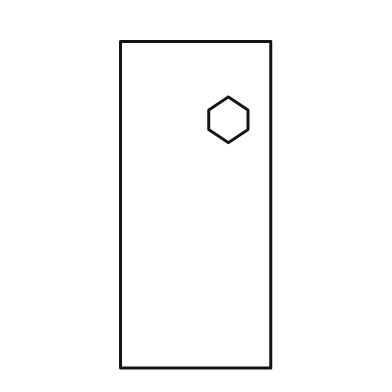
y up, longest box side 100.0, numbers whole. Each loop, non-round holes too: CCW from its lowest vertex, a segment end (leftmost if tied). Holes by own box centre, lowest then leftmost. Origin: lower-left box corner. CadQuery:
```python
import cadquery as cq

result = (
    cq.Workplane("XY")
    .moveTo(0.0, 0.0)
    .lineTo(46.0, 0.0)
    .lineTo(46.0, 100.0)
    .lineTo(0.0, 100.0)
    .close()
    .moveTo(33.0, 69.0)
    .lineTo(39.0, 73.0)
    .lineTo(39.0, 79.0)
    .lineTo(33.0, 83.0)
    .lineTo(27.0, 79.0)
    .lineTo(27.0, 73.0)
    .close()
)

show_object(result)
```